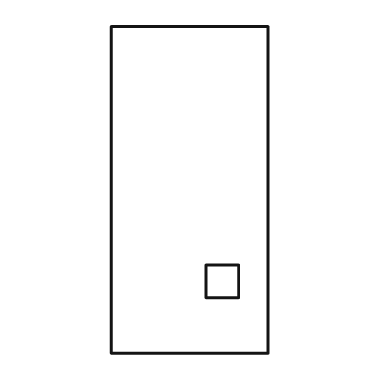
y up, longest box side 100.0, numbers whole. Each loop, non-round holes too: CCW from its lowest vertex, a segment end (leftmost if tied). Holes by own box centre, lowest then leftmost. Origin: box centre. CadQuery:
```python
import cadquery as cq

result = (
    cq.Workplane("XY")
    .moveTo(-24.0, -50.0)
    .lineTo(24.0, -50.0)
    .lineTo(24.0, 50.0)
    .lineTo(-24.0, 50.0)
    .close()
    .moveTo(5.0, -33.0)
    .lineTo(15.0, -33.0)
    .lineTo(15.0, -23.0)
    .lineTo(5.0, -23.0)
    .close()
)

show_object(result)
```